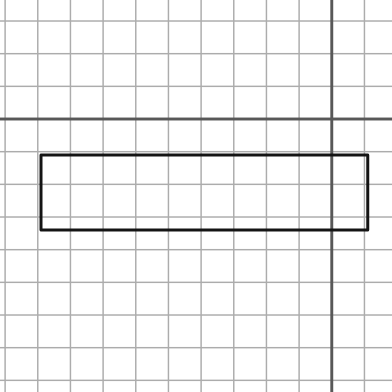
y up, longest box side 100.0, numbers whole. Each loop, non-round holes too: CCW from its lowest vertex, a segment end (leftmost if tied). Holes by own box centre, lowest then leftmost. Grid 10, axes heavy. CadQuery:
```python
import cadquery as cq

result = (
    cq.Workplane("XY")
    .moveTo(-89.0, -34.0)
    .lineTo(11.0, -34.0)
    .lineTo(11.0, -11.0)
    .lineTo(-89.0, -11.0)
    .close()
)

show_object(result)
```